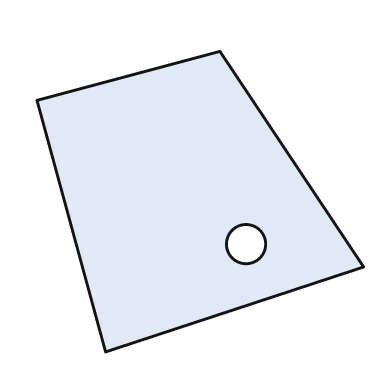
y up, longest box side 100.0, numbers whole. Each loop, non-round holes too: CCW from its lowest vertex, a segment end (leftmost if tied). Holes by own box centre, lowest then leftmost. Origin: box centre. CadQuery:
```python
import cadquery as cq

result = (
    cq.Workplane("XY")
    .moveTo(-29.0, -46.0)
    .lineTo(50.0, -20.0)
    .lineTo(6.0, 46.0)
    .lineTo(-50.0, 31.0)
    .close()
    .moveTo(14.0, -13.0)
    .circle(6.0)
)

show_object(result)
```